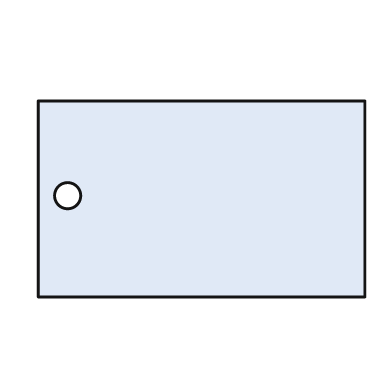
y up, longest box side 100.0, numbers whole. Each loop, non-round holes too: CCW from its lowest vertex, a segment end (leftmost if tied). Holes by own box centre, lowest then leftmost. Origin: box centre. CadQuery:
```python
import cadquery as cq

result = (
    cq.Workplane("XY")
    .moveTo(-50.0, -30.0)
    .lineTo(50.0, -30.0)
    .lineTo(50.0, 30.0)
    .lineTo(-50.0, 30.0)
    .close()
    .moveTo(-41.0, 1.0)
    .circle(4.0)
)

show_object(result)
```